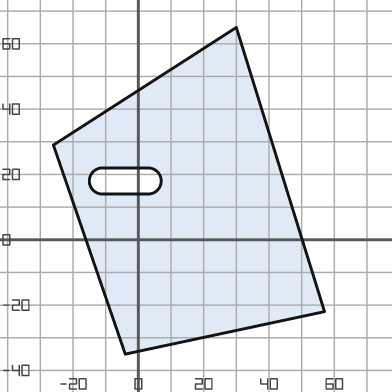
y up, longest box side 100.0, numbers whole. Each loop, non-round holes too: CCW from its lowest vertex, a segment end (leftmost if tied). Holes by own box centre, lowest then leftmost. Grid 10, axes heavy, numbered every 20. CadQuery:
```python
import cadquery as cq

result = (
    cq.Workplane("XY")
    .moveTo(-4.0, -35.0)
    .lineTo(57.0, -22.0)
    .lineTo(30.0, 65.0)
    .lineTo(-26.0, 29.0)
    .close()
    .moveTo(-11.0, 14.0)
    .lineTo(3.0, 14.0)
    .threePointArc((7.0, 18.0), (3.0, 22.0))
    .lineTo(-11.0, 22.0)
    .threePointArc((-15.0, 18.0), (-11.0, 14.0))
    .close()
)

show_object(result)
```